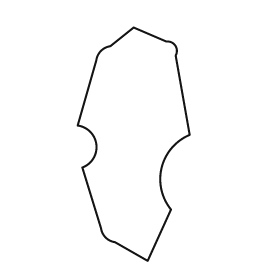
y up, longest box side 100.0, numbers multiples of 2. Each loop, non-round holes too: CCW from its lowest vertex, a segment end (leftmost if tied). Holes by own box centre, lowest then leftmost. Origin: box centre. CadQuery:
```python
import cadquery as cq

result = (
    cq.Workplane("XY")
    .moveTo(6.0, -50.0)
    .lineTo(16.0, -28.0)
    .threePointArc((12.0, -10.0), (24.0, 4.0))
    .lineTo(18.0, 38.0)
    .threePointArc((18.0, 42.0), (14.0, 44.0))
    .lineTo(0.0, 50.0)
    .lineTo(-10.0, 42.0)
    .threePointArc((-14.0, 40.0), (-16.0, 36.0))
    .lineTo(-24.0, 8.0)
    .threePointArc((-16.0, 0.0), (-22.0, -10.0))
    .lineTo(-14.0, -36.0)
    .threePointArc((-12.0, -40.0), (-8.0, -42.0))
    .close()
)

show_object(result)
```